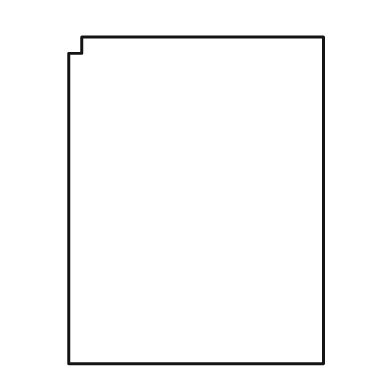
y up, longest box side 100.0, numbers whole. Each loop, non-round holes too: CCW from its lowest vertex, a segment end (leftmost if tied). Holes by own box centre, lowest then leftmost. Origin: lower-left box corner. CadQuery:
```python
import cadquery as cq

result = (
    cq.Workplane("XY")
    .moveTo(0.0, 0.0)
    .lineTo(78.0, 0.0)
    .lineTo(78.0, 100.0)
    .lineTo(4.0, 100.0)
    .lineTo(4.0, 95.0)
    .lineTo(0.0, 95.0)
    .close()
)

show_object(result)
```